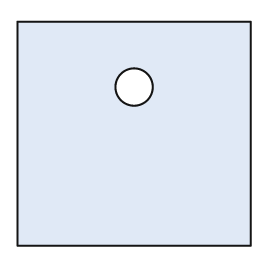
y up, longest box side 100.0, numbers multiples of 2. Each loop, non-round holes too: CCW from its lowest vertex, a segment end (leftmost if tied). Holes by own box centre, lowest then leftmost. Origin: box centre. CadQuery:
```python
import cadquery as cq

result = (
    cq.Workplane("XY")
    .moveTo(-50.0, -48.0)
    .lineTo(50.0, -48.0)
    .lineTo(50.0, 48.0)
    .lineTo(-50.0, 48.0)
    .close()
    .moveTo(0.0, 20.0)
    .circle(8.0)
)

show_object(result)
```